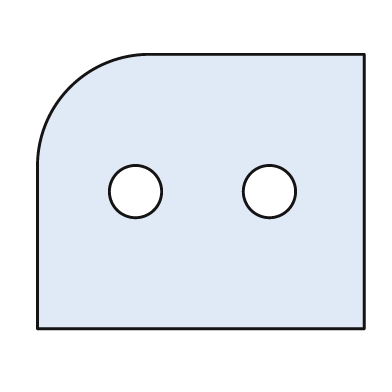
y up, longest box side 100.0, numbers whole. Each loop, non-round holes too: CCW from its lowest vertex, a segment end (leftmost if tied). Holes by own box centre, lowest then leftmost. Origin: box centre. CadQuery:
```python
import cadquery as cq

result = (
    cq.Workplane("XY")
    .moveTo(-50.0, -42.0)
    .lineTo(50.0, -42.0)
    .lineTo(50.0, 42.0)
    .lineTo(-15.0, 42.0)
    .threePointArc((-40.0, 32.0), (-50.0, 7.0))
    .close()
    .moveTo(-20.0, 0.0)
    .circle(8.0)
    .moveTo(21.0, 0.0)
    .circle(8.0)
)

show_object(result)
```